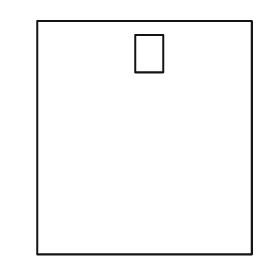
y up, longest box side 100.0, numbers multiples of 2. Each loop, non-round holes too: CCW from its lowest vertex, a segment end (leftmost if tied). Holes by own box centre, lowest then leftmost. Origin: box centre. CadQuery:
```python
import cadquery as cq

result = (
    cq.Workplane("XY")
    .moveTo(-46.0, -50.0)
    .lineTo(46.0, -50.0)
    .lineTo(46.0, 50.0)
    .lineTo(-46.0, 50.0)
    .close()
    .moveTo(-4.0, 28.0)
    .lineTo(8.0, 28.0)
    .lineTo(8.0, 44.0)
    .lineTo(-4.0, 44.0)
    .close()
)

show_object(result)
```